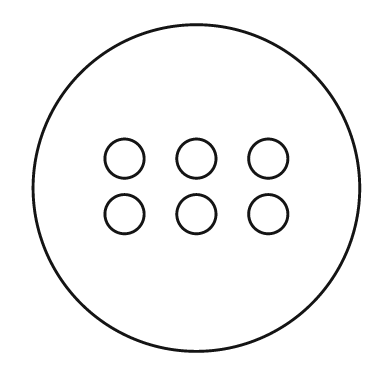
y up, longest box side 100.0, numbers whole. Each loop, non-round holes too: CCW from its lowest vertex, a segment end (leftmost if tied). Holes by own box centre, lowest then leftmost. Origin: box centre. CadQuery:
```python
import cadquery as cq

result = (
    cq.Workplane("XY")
    .moveTo(0.0, 0.0)
    .circle(50.0)
    .moveTo(-22.0, -8.0)
    .circle(6.0)
    .moveTo(0.0, -8.0)
    .circle(6.0)
    .moveTo(22.0, -8.0)
    .circle(6.0)
    .moveTo(-22.0, 9.0)
    .circle(6.0)
    .moveTo(0.0, 9.0)
    .circle(6.0)
    .moveTo(22.0, 9.0)
    .circle(6.0)
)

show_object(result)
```